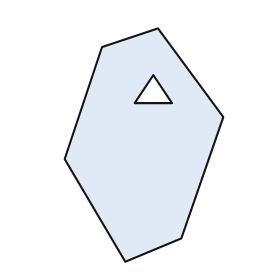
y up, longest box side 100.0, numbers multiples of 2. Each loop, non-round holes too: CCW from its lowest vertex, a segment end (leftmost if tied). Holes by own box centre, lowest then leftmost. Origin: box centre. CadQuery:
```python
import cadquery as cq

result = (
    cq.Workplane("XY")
    .moveTo(-8.0, -50.0)
    .lineTo(16.0, -40.0)
    .lineTo(34.0, 12.0)
    .lineTo(6.0, 50.0)
    .lineTo(-18.0, 42.0)
    .lineTo(-34.0, -6.0)
    .close()
    .moveTo(-4.0, 18.0)
    .lineTo(12.0, 18.0)
    .lineTo(4.0, 30.0)
    .close()
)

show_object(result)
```